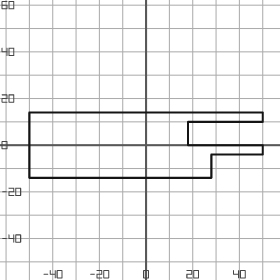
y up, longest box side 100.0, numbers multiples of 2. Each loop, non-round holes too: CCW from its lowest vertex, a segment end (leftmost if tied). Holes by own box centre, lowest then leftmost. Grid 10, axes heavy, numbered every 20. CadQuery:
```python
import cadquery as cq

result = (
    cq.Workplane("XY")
    .moveTo(-50.0, -14.0)
    .lineTo(28.0, -14.0)
    .lineTo(28.0, -4.0)
    .lineTo(50.0, -4.0)
    .lineTo(50.0, 0.0)
    .lineTo(18.0, 0.0)
    .lineTo(18.0, 10.0)
    .lineTo(50.0, 10.0)
    .lineTo(50.0, 14.0)
    .lineTo(-50.0, 14.0)
    .close()
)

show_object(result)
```